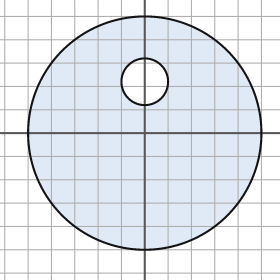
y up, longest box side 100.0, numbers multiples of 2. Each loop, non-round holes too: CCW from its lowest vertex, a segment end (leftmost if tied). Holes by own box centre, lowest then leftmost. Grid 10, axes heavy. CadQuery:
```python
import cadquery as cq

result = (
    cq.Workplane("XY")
    .moveTo(0.0, 0.0)
    .circle(50.0)
    .moveTo(0.0, 22.0)
    .circle(10.0)
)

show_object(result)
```